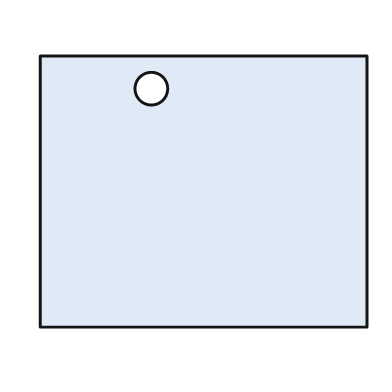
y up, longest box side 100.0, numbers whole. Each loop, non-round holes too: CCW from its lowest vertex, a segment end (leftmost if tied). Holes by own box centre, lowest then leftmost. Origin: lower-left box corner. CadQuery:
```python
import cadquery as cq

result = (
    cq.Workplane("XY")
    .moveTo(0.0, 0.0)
    .lineTo(100.0, 0.0)
    .lineTo(100.0, 83.0)
    .lineTo(0.0, 83.0)
    .close()
    .moveTo(34.0, 73.0)
    .circle(5.0)
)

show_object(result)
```